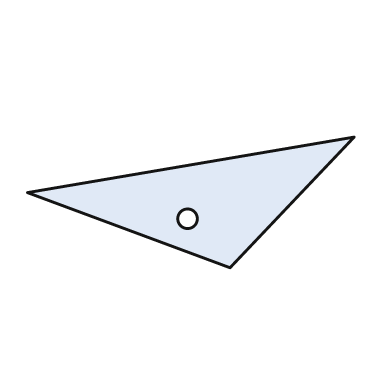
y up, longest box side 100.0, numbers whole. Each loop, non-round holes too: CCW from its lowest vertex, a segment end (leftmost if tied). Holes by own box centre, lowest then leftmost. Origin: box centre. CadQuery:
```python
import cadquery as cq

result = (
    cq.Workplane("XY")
    .moveTo(12.0, -20.0)
    .lineTo(50.0, 20.0)
    .lineTo(-50.0, 3.0)
    .close()
    .moveTo(-1.0, -5.0)
    .circle(3.0)
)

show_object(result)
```